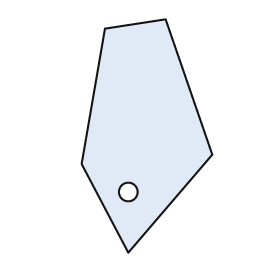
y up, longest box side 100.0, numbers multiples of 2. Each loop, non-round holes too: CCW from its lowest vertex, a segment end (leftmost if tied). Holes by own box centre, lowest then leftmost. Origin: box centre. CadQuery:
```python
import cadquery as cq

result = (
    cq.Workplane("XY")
    .moveTo(-8.0, -50.0)
    .lineTo(28.0, -8.0)
    .lineTo(8.0, 50.0)
    .lineTo(-18.0, 46.0)
    .lineTo(-28.0, -12.0)
    .close()
    .moveTo(-8.0, -24.0)
    .circle(4.0)
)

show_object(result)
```